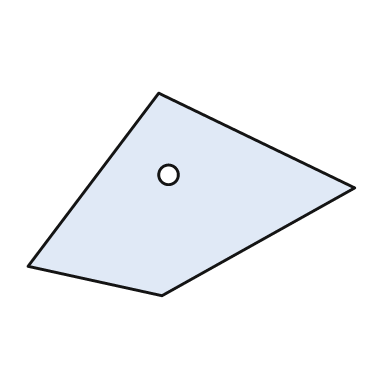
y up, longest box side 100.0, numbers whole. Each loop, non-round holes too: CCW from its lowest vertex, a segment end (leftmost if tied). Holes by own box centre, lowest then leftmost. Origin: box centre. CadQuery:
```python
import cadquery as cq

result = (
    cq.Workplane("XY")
    .moveTo(-9.0, -31.0)
    .lineTo(50.0, 2.0)
    .lineTo(-10.0, 31.0)
    .lineTo(-50.0, -22.0)
    .close()
    .moveTo(-7.0, 6.0)
    .circle(3.0)
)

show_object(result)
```